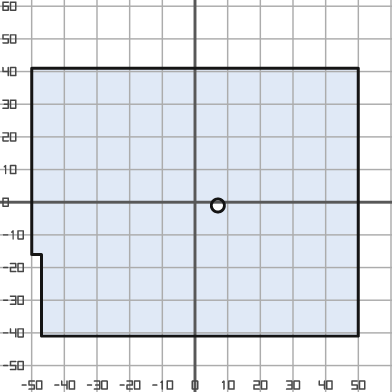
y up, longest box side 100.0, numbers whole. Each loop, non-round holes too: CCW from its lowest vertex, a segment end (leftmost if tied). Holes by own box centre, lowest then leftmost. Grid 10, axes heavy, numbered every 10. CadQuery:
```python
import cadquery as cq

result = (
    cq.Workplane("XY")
    .moveTo(-47.0, -41.0)
    .lineTo(50.0, -41.0)
    .lineTo(50.0, 41.0)
    .lineTo(-50.0, 41.0)
    .lineTo(-50.0, -16.0)
    .lineTo(-47.0, -16.0)
    .close()
    .moveTo(7.0, -1.0)
    .circle(2.0)
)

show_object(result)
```